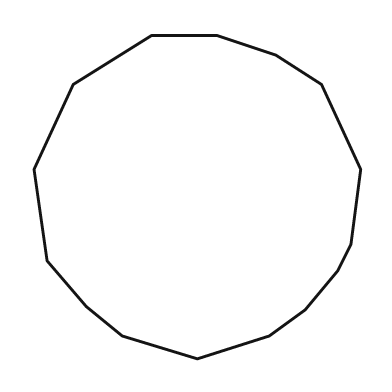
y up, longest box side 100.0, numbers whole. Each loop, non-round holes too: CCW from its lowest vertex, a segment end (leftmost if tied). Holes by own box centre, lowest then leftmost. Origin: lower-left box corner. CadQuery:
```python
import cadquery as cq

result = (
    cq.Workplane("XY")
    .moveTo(50.0, 0.0)
    .lineTo(72.0, 7.0)
    .lineTo(83.0, 15.0)
    .lineTo(93.0, 27.0)
    .lineTo(97.0, 35.0)
    .lineTo(100.0, 58.0)
    .lineTo(88.0, 84.0)
    .lineTo(74.0, 93.0)
    .lineTo(56.0, 99.0)
    .lineTo(36.0, 99.0)
    .lineTo(12.0, 84.0)
    .lineTo(0.0, 58.0)
    .lineTo(4.0, 30.0)
    .lineTo(16.0, 16.0)
    .lineTo(27.0, 7.0)
    .close()
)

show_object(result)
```